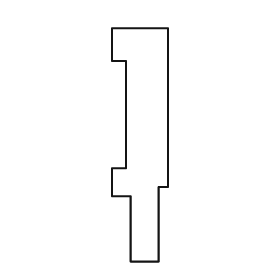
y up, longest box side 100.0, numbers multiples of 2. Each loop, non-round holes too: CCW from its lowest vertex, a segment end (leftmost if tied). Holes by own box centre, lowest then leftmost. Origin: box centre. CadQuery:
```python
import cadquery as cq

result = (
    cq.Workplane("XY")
    .moveTo(-4.0, -50.0)
    .lineTo(8.0, -50.0)
    .lineTo(8.0, -18.0)
    .lineTo(12.0, -18.0)
    .lineTo(12.0, 50.0)
    .lineTo(-12.0, 50.0)
    .lineTo(-12.0, 36.0)
    .lineTo(-6.0, 36.0)
    .lineTo(-6.0, -10.0)
    .lineTo(-12.0, -10.0)
    .lineTo(-12.0, -22.0)
    .lineTo(-4.0, -22.0)
    .close()
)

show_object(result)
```